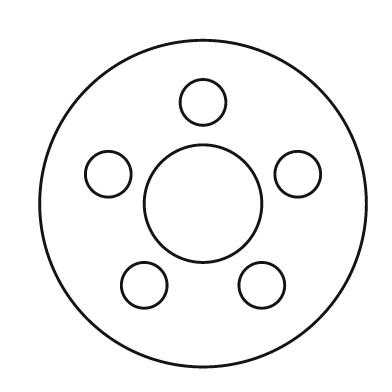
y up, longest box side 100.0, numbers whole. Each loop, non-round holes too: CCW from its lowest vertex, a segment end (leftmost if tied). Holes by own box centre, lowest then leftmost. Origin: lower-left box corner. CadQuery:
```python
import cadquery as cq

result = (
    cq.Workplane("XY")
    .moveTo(50.0, 50.0)
    .circle(50.0)
    .moveTo(32.0, 25.0)
    .circle(7.0)
    .moveTo(68.0, 25.0)
    .circle(7.0)
    .moveTo(50.0, 50.0)
    .circle(18.0)
    .moveTo(21.0, 59.0)
    .circle(7.0)
    .moveTo(79.0, 59.0)
    .circle(7.0)
    .moveTo(50.0, 81.0)
    .circle(7.0)
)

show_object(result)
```